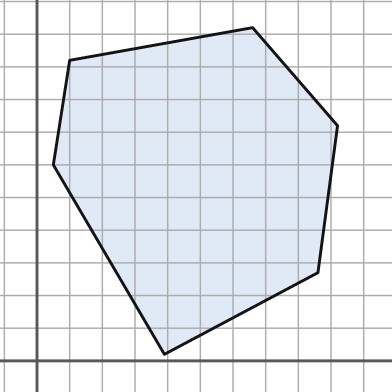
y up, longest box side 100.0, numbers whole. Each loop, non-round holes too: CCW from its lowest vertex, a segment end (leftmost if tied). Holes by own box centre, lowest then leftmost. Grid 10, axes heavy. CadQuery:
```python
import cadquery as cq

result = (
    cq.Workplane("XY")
    .moveTo(39.0, 2.0)
    .lineTo(86.0, 27.0)
    .lineTo(92.0, 72.0)
    .lineTo(66.0, 102.0)
    .lineTo(10.0, 92.0)
    .lineTo(5.0, 60.0)
    .close()
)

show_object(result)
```